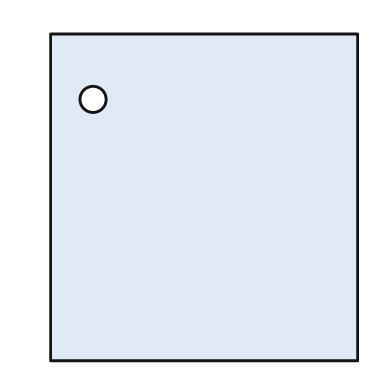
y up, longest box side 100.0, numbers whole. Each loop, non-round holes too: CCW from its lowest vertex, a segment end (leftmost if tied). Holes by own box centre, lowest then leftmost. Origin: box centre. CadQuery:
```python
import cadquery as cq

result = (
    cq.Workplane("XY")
    .moveTo(-47.0, -50.0)
    .lineTo(47.0, -50.0)
    .lineTo(47.0, 50.0)
    .lineTo(-47.0, 50.0)
    .close()
    .moveTo(-34.0, 30.0)
    .circle(4.0)
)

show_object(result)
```